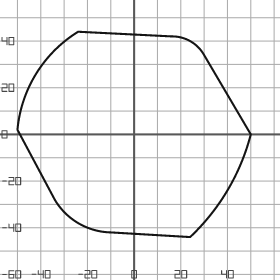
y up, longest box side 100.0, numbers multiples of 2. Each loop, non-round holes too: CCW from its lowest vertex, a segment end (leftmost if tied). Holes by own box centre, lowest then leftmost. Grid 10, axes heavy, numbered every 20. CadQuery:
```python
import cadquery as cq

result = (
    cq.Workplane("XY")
    .moveTo(24.0, -44.0)
    .threePointArc((40.0, -24.0), (50.0, 0.0))
    .lineTo(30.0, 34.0)
    .threePointArc((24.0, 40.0), (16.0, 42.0))
    .lineTo(-24.0, 44.0)
    .threePointArc((-42.0, 26.0), (-50.0, 2.0))
    .lineTo(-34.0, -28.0)
    .threePointArc((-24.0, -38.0), (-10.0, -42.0))
    .close()
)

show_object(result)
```